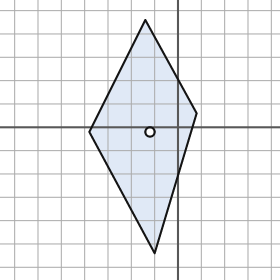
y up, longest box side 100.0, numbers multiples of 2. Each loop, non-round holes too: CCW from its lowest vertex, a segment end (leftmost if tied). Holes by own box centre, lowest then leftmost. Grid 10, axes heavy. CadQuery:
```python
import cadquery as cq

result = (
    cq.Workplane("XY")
    .moveTo(-10.0, -54.0)
    .lineTo(8.0, 6.0)
    .lineTo(-14.0, 46.0)
    .lineTo(-38.0, -2.0)
    .close()
    .moveTo(-12.0, -2.0)
    .circle(2.0)
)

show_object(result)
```